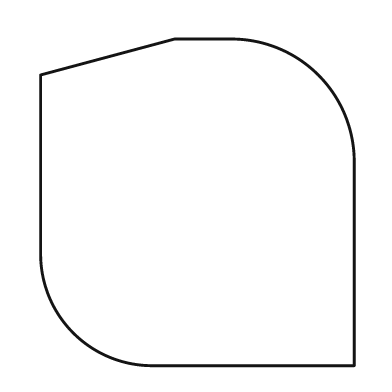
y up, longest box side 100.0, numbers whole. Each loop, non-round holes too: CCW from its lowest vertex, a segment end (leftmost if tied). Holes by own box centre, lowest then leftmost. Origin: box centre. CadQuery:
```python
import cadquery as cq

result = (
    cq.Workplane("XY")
    .moveTo(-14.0, -50.0)
    .lineTo(48.0, -50.0)
    .lineTo(48.0, 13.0)
    .threePointArc((37.0, 39.0), (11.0, 50.0))
    .lineTo(-7.0, 50.0)
    .lineTo(-48.0, 39.0)
    .lineTo(-48.0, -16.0)
    .threePointArc((-38.0, -40.0), (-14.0, -50.0))
    .close()
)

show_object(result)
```